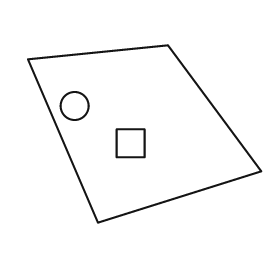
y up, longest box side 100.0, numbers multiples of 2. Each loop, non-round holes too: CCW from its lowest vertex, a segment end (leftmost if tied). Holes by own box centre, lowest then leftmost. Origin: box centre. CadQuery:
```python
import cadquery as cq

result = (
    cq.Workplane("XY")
    .moveTo(-20.0, -38.0)
    .lineTo(50.0, -16.0)
    .lineTo(10.0, 38.0)
    .lineTo(-50.0, 32.0)
    .close()
    .moveTo(-12.0, -10.0)
    .lineTo(0.0, -10.0)
    .lineTo(0.0, 2.0)
    .lineTo(-12.0, 2.0)
    .close()
    .moveTo(-30.0, 12.0)
    .circle(6.0)
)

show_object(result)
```